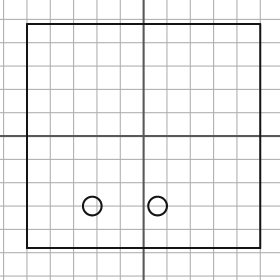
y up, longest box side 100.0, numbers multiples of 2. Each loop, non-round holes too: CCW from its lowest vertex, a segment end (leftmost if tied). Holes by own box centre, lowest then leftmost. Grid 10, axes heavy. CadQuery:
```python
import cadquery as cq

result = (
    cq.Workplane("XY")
    .moveTo(-50.0, -48.0)
    .lineTo(50.0, -48.0)
    .lineTo(50.0, 48.0)
    .lineTo(-50.0, 48.0)
    .close()
    .moveTo(-22.0, -30.0)
    .circle(4.0)
    .moveTo(6.0, -30.0)
    .circle(4.0)
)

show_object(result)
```